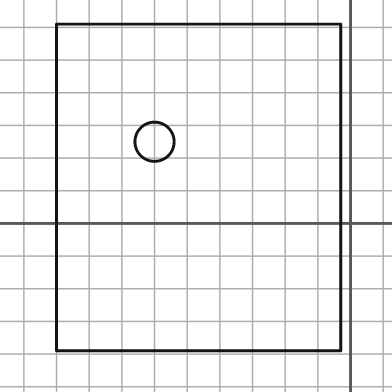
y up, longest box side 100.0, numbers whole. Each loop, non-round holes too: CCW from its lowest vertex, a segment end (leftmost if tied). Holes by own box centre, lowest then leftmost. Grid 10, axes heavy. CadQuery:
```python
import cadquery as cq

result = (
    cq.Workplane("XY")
    .moveTo(-90.0, -39.0)
    .lineTo(-3.0, -39.0)
    .lineTo(-3.0, 61.0)
    .lineTo(-90.0, 61.0)
    .close()
    .moveTo(-60.0, 25.0)
    .circle(6.0)
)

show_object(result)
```